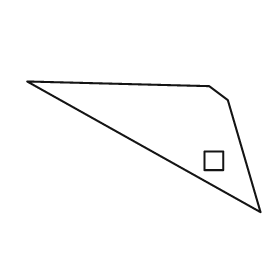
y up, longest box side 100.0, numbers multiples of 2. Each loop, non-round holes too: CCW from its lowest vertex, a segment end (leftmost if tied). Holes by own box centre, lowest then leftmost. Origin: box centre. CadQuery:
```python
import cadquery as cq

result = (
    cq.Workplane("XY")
    .moveTo(50.0, -28.0)
    .lineTo(36.0, 20.0)
    .lineTo(28.0, 26.0)
    .lineTo(-50.0, 28.0)
    .close()
    .moveTo(26.0, -10.0)
    .lineTo(34.0, -10.0)
    .lineTo(34.0, -2.0)
    .lineTo(26.0, -2.0)
    .close()
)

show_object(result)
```